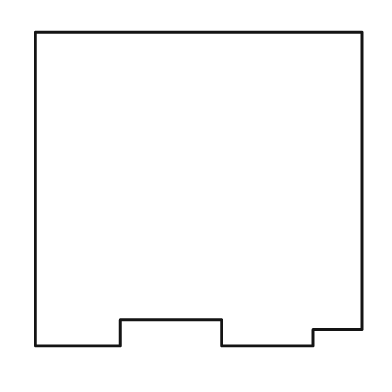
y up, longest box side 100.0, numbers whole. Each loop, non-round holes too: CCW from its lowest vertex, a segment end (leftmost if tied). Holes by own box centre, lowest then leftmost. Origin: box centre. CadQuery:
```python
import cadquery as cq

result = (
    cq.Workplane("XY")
    .moveTo(-50.0, -48.0)
    .lineTo(-24.0, -48.0)
    .lineTo(-24.0, -40.0)
    .lineTo(7.0, -40.0)
    .lineTo(7.0, -48.0)
    .lineTo(35.0, -48.0)
    .lineTo(35.0, -43.0)
    .lineTo(50.0, -43.0)
    .lineTo(50.0, 48.0)
    .lineTo(-50.0, 48.0)
    .close()
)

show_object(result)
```